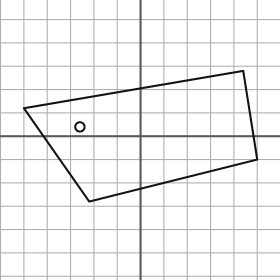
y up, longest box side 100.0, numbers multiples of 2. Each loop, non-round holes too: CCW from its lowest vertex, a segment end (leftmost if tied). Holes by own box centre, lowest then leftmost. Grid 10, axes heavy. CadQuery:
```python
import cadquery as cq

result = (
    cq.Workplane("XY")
    .moveTo(-22.0, -28.0)
    .lineTo(50.0, -10.0)
    .lineTo(44.0, 28.0)
    .lineTo(-50.0, 12.0)
    .close()
    .moveTo(-26.0, 4.0)
    .circle(2.0)
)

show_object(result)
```